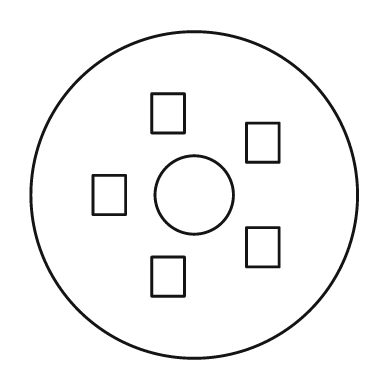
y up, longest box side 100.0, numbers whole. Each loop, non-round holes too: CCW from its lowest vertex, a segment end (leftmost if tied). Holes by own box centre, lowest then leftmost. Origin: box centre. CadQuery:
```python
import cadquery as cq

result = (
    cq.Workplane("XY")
    .moveTo(0.0, 0.0)
    .circle(50.0)
    .moveTo(-13.0, -31.0)
    .lineTo(-3.0, -31.0)
    .lineTo(-3.0, -19.0)
    .lineTo(-13.0, -19.0)
    .close()
    .moveTo(16.0, -22.0)
    .lineTo(26.0, -22.0)
    .lineTo(26.0, -10.0)
    .lineTo(16.0, -10.0)
    .close()
    .moveTo(-31.0, -6.0)
    .lineTo(-21.0, -6.0)
    .lineTo(-21.0, 6.0)
    .lineTo(-31.0, 6.0)
    .close()
    .moveTo(0.0, 0.0)
    .circle(12.0)
    .moveTo(16.0, 10.0)
    .lineTo(26.0, 10.0)
    .lineTo(26.0, 22.0)
    .lineTo(16.0, 22.0)
    .close()
    .moveTo(-13.0, 19.0)
    .lineTo(-3.0, 19.0)
    .lineTo(-3.0, 31.0)
    .lineTo(-13.0, 31.0)
    .close()
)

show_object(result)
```